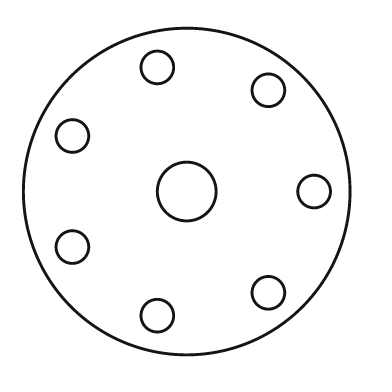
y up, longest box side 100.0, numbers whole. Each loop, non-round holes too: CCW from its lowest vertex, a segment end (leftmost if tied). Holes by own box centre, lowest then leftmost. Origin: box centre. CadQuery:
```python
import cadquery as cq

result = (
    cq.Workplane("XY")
    .moveTo(0.0, 0.0)
    .circle(50.0)
    .moveTo(-9.0, -38.0)
    .circle(5.0)
    .moveTo(25.0, -31.0)
    .circle(5.0)
    .moveTo(-35.0, -17.0)
    .circle(5.0)
    .moveTo(0.0, 0.0)
    .circle(9.0)
    .moveTo(39.0, 0.0)
    .circle(5.0)
    .moveTo(-35.0, 17.0)
    .circle(5.0)
    .moveTo(25.0, 31.0)
    .circle(5.0)
    .moveTo(-9.0, 38.0)
    .circle(5.0)
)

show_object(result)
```